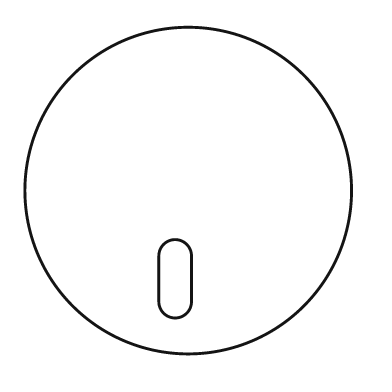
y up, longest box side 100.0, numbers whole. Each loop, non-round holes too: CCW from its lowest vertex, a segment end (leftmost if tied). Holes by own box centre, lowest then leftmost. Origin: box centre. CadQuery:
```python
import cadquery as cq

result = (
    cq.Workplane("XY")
    .moveTo(0.0, 0.0)
    .circle(50.0)
    .moveTo(-9.0, -34.0)
    .threePointArc((-4.0, -39.0), (1.0, -34.0))
    .lineTo(1.0, -20.0)
    .threePointArc((-4.0, -15.0), (-9.0, -20.0))
    .close()
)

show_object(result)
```